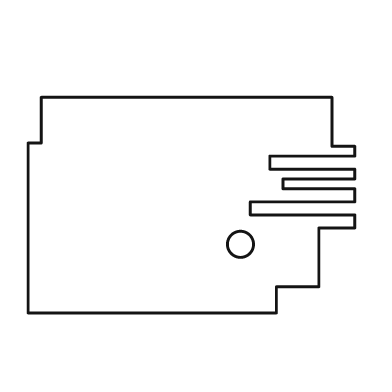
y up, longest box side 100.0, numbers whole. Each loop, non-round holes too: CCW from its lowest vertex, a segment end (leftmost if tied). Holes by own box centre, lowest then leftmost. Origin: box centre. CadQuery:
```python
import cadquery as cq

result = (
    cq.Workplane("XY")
    .moveTo(-50.0, -33.0)
    .lineTo(26.0, -33.0)
    .lineTo(26.0, -25.0)
    .lineTo(39.0, -25.0)
    .lineTo(39.0, -7.0)
    .lineTo(50.0, -7.0)
    .lineTo(50.0, -3.0)
    .lineTo(18.0, -3.0)
    .lineTo(18.0, 1.0)
    .lineTo(50.0, 1.0)
    .lineTo(50.0, 5.0)
    .lineTo(28.0, 5.0)
    .lineTo(28.0, 8.0)
    .lineTo(50.0, 8.0)
    .lineTo(50.0, 11.0)
    .lineTo(24.0, 11.0)
    .lineTo(24.0, 15.0)
    .lineTo(50.0, 15.0)
    .lineTo(50.0, 18.0)
    .lineTo(43.0, 18.0)
    .lineTo(43.0, 33.0)
    .lineTo(-46.0, 33.0)
    .lineTo(-46.0, 19.0)
    .lineTo(-50.0, 19.0)
    .close()
    .moveTo(15.0, -12.0)
    .circle(4.0)
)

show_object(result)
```